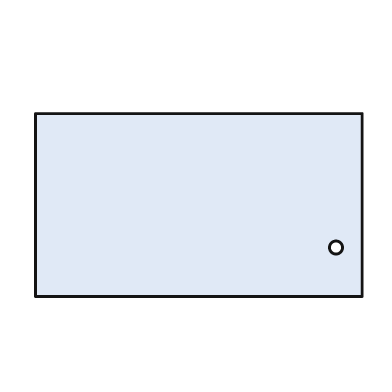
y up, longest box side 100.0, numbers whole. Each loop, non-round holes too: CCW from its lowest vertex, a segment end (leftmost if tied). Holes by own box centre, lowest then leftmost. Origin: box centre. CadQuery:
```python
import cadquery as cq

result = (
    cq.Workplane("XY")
    .moveTo(-50.0, -28.0)
    .lineTo(50.0, -28.0)
    .lineTo(50.0, 28.0)
    .lineTo(-50.0, 28.0)
    .close()
    .moveTo(42.0, -13.0)
    .circle(2.0)
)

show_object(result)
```